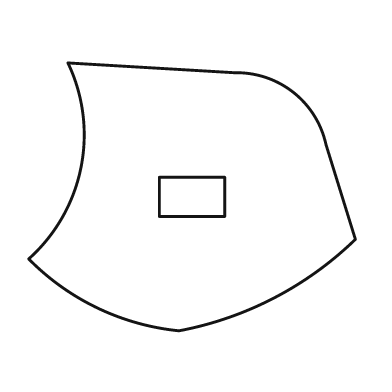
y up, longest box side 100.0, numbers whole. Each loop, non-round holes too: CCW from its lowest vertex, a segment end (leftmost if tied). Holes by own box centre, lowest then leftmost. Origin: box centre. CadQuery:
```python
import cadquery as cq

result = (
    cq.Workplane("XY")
    .moveTo(-4.0, -41.0)
    .threePointArc((25.0, -31.0), (50.0, -13.0))
    .lineTo(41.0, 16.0)
    .threePointArc((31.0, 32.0), (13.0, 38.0))
    .lineTo(-38.0, 41.0)
    .threePointArc((-34.0, 9.0), (-50.0, -19.0))
    .threePointArc((-29.0, -34.0), (-4.0, -41.0))
    .close()
    .moveTo(-10.0, -6.0)
    .lineTo(10.0, -6.0)
    .lineTo(10.0, 6.0)
    .lineTo(-10.0, 6.0)
    .close()
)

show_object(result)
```